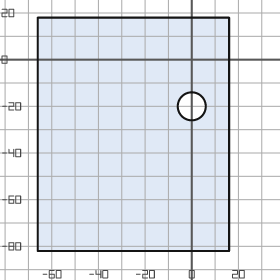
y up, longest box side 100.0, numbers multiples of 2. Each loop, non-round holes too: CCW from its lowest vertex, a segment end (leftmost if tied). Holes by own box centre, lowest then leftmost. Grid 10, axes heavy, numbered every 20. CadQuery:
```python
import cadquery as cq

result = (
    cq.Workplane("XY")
    .moveTo(-66.0, -82.0)
    .lineTo(16.0, -82.0)
    .lineTo(16.0, 18.0)
    .lineTo(-66.0, 18.0)
    .close()
    .moveTo(0.0, -20.0)
    .circle(6.0)
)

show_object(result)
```